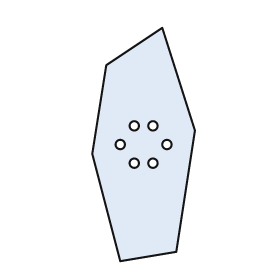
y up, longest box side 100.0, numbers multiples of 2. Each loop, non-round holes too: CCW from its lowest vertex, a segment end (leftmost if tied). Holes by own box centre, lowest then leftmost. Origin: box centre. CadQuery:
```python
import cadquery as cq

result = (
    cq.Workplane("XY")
    .moveTo(-10.0, -50.0)
    .lineTo(14.0, -46.0)
    .lineTo(22.0, 6.0)
    .lineTo(8.0, 50.0)
    .lineTo(-16.0, 34.0)
    .lineTo(-22.0, -4.0)
    .close()
    .moveTo(-4.0, -8.0)
    .circle(2.0)
    .moveTo(4.0, -8.0)
    .circle(2.0)
    .moveTo(-10.0, 0.0)
    .circle(2.0)
    .moveTo(10.0, 0.0)
    .circle(2.0)
    .moveTo(-4.0, 8.0)
    .circle(2.0)
    .moveTo(4.0, 8.0)
    .circle(2.0)
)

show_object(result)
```